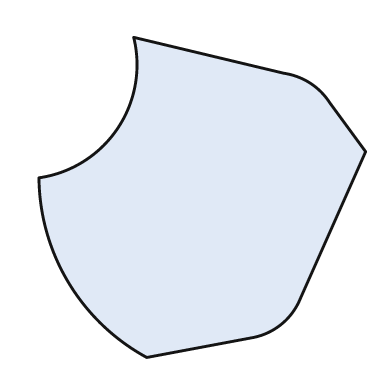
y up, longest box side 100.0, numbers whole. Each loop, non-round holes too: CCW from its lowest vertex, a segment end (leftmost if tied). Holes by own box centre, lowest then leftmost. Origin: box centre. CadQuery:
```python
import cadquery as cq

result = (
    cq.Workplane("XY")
    .moveTo(-17.0, -49.0)
    .lineTo(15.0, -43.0)
    .threePointArc((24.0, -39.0), (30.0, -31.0))
    .lineTo(50.0, 14.0)
    .lineTo(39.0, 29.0)
    .threePointArc((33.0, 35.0), (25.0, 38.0))
    .lineTo(-21.0, 49.0)
    .threePointArc((-26.0, 21.0), (-50.0, 6.0))
    .threePointArc((-41.0, -26.0), (-17.0, -49.0))
    .close()
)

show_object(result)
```